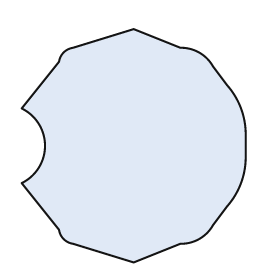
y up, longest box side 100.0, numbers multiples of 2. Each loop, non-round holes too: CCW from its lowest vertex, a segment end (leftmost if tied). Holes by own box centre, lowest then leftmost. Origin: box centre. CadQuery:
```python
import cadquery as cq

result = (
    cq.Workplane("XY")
    .moveTo(0.0, -50.0)
    .lineTo(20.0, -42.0)
    .threePointArc((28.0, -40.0), (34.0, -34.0))
    .lineTo(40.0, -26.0)
    .threePointArc((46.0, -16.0), (48.0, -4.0))
    .lineTo(48.0, 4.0)
    .threePointArc((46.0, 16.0), (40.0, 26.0))
    .lineTo(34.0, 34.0)
    .threePointArc((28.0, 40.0), (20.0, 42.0))
    .lineTo(0.0, 50.0)
    .lineTo(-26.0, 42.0)
    .threePointArc((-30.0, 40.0), (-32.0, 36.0))
    .lineTo(-48.0, 16.0)
    .threePointArc((-38.0, 0.0), (-48.0, -16.0))
    .lineTo(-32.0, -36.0)
    .threePointArc((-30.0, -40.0), (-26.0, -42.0))
    .close()
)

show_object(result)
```